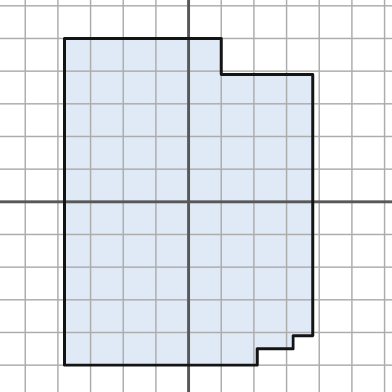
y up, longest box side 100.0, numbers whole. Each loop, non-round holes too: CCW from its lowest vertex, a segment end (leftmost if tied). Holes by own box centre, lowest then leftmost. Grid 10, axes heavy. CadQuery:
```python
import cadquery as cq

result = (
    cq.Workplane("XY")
    .moveTo(-38.0, -50.0)
    .lineTo(21.0, -50.0)
    .lineTo(21.0, -45.0)
    .lineTo(32.0, -45.0)
    .lineTo(32.0, -41.0)
    .lineTo(38.0, -41.0)
    .lineTo(38.0, 39.0)
    .lineTo(10.0, 39.0)
    .lineTo(10.0, 50.0)
    .lineTo(-38.0, 50.0)
    .close()
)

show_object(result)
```